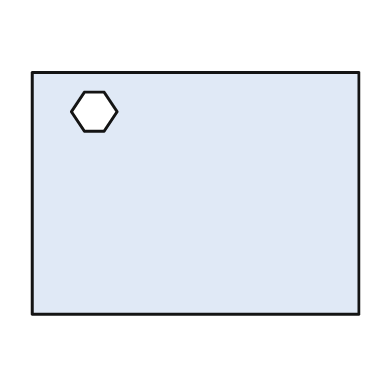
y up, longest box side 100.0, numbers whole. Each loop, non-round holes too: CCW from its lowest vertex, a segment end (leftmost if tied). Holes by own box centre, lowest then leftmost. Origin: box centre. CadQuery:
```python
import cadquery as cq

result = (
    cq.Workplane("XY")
    .moveTo(-50.0, -37.0)
    .lineTo(50.0, -37.0)
    .lineTo(50.0, 37.0)
    .lineTo(-50.0, 37.0)
    .close()
    .moveTo(-34.0, 19.0)
    .lineTo(-28.0, 19.0)
    .lineTo(-24.0, 25.0)
    .lineTo(-28.0, 31.0)
    .lineTo(-34.0, 31.0)
    .lineTo(-38.0, 25.0)
    .close()
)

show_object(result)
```